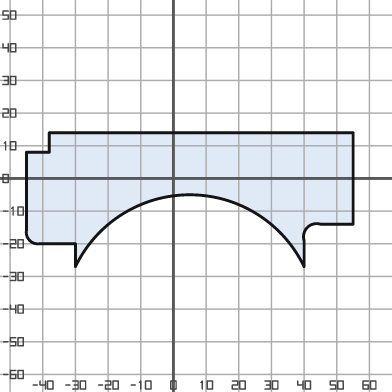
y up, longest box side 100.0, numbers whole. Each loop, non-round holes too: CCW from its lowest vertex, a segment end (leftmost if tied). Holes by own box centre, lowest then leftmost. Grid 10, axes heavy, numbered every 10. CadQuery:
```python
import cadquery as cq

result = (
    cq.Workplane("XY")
    .moveTo(-30.0, -27.0)
    .threePointArc((5.0, -5.0), (40.0, -27.0))
    .lineTo(40.0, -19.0)
    .threePointArc((41.0, -15.0), (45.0, -14.0))
    .lineTo(55.0, -14.0)
    .lineTo(55.0, 14.0)
    .lineTo(-38.0, 14.0)
    .lineTo(-38.0, 8.0)
    .lineTo(-45.0, 8.0)
    .lineTo(-45.0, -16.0)
    .threePointArc((-44.0, -19.0), (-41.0, -20.0))
    .lineTo(-30.0, -20.0)
    .close()
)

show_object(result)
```